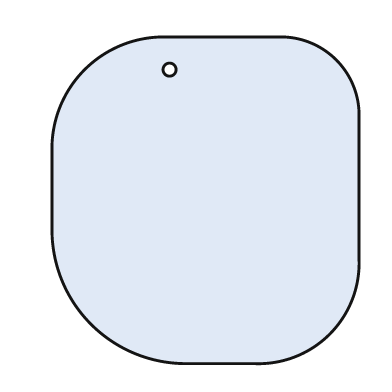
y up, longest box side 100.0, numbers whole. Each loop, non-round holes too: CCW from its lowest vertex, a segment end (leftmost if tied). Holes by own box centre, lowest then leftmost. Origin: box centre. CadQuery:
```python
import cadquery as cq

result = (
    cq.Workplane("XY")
    .moveTo(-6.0, -50.0)
    .lineTo(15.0, -50.0)
    .threePointArc((38.0, -41.0), (47.0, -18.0))
    .lineTo(47.0, 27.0)
    .threePointArc((40.0, 43.0), (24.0, 50.0))
    .lineTo(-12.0, 50.0)
    .threePointArc((-37.0, 40.0), (-47.0, 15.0))
    .lineTo(-47.0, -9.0)
    .threePointArc((-35.0, -38.0), (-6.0, -50.0))
    .close()
    .moveTo(-11.0, 40.0)
    .circle(2.0)
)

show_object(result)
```